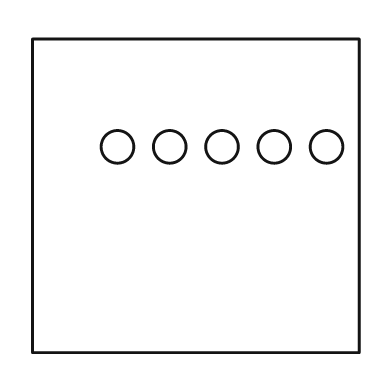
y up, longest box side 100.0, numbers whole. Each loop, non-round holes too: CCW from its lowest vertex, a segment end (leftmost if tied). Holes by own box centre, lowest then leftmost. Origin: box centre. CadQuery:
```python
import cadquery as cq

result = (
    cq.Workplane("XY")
    .moveTo(-50.0, -48.0)
    .lineTo(50.0, -48.0)
    .lineTo(50.0, 48.0)
    .lineTo(-50.0, 48.0)
    .close()
    .moveTo(-24.0, 15.0)
    .circle(5.0)
    .moveTo(-8.0, 15.0)
    .circle(5.0)
    .moveTo(8.0, 15.0)
    .circle(5.0)
    .moveTo(24.0, 15.0)
    .circle(5.0)
    .moveTo(40.0, 15.0)
    .circle(5.0)
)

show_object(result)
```